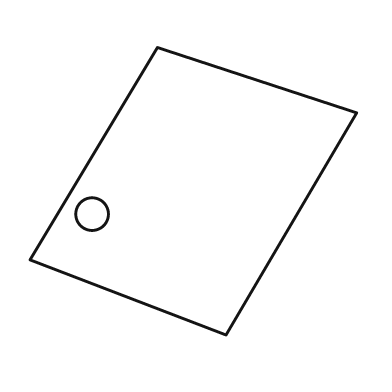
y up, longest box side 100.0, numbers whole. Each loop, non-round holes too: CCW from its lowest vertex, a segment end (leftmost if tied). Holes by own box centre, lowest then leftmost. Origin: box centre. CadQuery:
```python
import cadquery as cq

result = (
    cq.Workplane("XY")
    .moveTo(10.0, -44.0)
    .lineTo(50.0, 24.0)
    .lineTo(-11.0, 44.0)
    .lineTo(-50.0, -21.0)
    .close()
    .moveTo(-31.0, -7.0)
    .circle(5.0)
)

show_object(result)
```